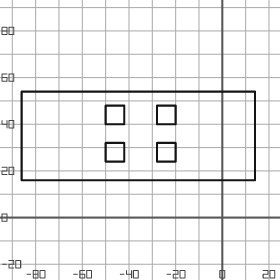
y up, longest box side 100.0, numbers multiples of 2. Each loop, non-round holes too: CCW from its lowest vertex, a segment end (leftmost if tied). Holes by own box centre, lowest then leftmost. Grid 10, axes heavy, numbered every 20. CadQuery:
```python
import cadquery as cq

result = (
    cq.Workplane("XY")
    .moveTo(-86.0, 16.0)
    .lineTo(14.0, 16.0)
    .lineTo(14.0, 54.0)
    .lineTo(-86.0, 54.0)
    .close()
    .moveTo(-50.0, 24.0)
    .lineTo(-42.0, 24.0)
    .lineTo(-42.0, 32.0)
    .lineTo(-50.0, 32.0)
    .close()
    .moveTo(-28.0, 24.0)
    .lineTo(-20.0, 24.0)
    .lineTo(-20.0, 32.0)
    .lineTo(-28.0, 32.0)
    .close()
    .moveTo(-50.0, 40.0)
    .lineTo(-42.0, 40.0)
    .lineTo(-42.0, 48.0)
    .lineTo(-50.0, 48.0)
    .close()
    .moveTo(-28.0, 40.0)
    .lineTo(-20.0, 40.0)
    .lineTo(-20.0, 48.0)
    .lineTo(-28.0, 48.0)
    .close()
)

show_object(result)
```